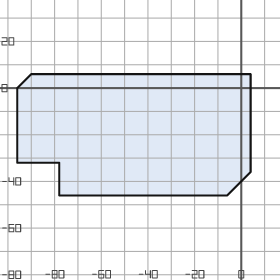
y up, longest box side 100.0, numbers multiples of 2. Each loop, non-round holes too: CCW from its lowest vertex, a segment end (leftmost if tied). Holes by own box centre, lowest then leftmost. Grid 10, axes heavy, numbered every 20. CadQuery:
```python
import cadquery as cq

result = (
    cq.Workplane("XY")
    .moveTo(-78.0, -46.0)
    .lineTo(-6.0, -46.0)
    .lineTo(4.0, -36.0)
    .lineTo(4.0, 6.0)
    .lineTo(-90.0, 6.0)
    .lineTo(-96.0, 0.0)
    .lineTo(-96.0, -32.0)
    .lineTo(-78.0, -32.0)
    .close()
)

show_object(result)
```